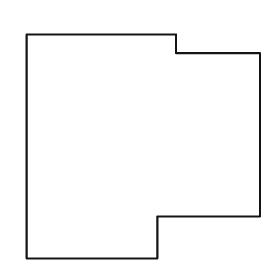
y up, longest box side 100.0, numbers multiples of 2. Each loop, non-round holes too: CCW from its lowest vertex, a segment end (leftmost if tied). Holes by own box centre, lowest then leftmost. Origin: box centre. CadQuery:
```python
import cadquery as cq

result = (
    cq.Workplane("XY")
    .moveTo(-50.0, -48.0)
    .lineTo(6.0, -48.0)
    .lineTo(6.0, -30.0)
    .lineTo(50.0, -30.0)
    .lineTo(50.0, 40.0)
    .lineTo(14.0, 40.0)
    .lineTo(14.0, 48.0)
    .lineTo(-50.0, 48.0)
    .close()
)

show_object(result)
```